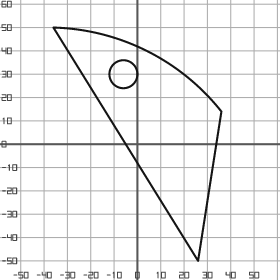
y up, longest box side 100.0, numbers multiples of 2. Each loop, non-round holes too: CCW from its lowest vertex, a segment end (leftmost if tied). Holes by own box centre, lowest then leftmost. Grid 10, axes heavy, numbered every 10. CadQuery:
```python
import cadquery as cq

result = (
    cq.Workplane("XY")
    .moveTo(26.0, -50.0)
    .lineTo(36.0, 14.0)
    .threePointArc((4.0, 40.0), (-36.0, 50.0))
    .close()
    .moveTo(-6.0, 30.0)
    .circle(6.0)
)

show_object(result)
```